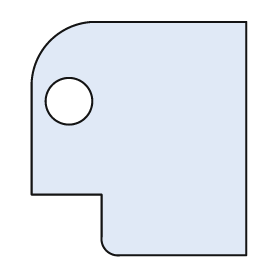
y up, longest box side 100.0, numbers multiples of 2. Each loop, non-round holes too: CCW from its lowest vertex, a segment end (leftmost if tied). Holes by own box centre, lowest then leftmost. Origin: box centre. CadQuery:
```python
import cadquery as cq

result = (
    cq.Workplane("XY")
    .moveTo(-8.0, -50.0)
    .lineTo(46.0, -50.0)
    .lineTo(46.0, 50.0)
    .lineTo(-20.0, 50.0)
    .threePointArc((-38.0, 42.0), (-46.0, 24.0))
    .lineTo(-46.0, -24.0)
    .lineTo(-16.0, -24.0)
    .lineTo(-16.0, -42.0)
    .threePointArc((-14.0, -48.0), (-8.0, -50.0))
    .close()
    .moveTo(-30.0, 16.0)
    .circle(10.0)
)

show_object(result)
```